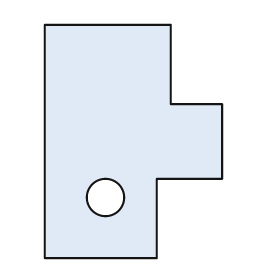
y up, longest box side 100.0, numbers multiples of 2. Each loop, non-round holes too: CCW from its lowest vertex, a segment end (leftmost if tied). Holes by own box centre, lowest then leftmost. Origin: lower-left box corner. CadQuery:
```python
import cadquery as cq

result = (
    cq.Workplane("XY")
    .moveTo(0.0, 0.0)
    .lineTo(48.0, 0.0)
    .lineTo(48.0, 34.0)
    .lineTo(76.0, 34.0)
    .lineTo(76.0, 66.0)
    .lineTo(54.0, 66.0)
    .lineTo(54.0, 100.0)
    .lineTo(0.0, 100.0)
    .close()
    .moveTo(26.0, 26.0)
    .circle(8.0)
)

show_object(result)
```